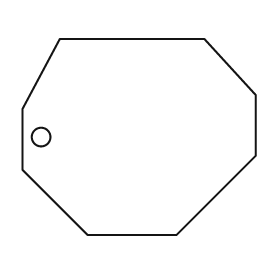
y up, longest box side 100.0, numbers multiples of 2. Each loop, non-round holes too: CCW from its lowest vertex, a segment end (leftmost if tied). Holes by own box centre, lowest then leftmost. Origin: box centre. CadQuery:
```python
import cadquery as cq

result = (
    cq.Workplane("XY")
    .moveTo(-22.0, -42.0)
    .lineTo(16.0, -42.0)
    .lineTo(50.0, -8.0)
    .lineTo(50.0, 18.0)
    .lineTo(28.0, 42.0)
    .lineTo(-34.0, 42.0)
    .lineTo(-50.0, 12.0)
    .lineTo(-50.0, -14.0)
    .close()
    .moveTo(-42.0, 0.0)
    .circle(4.0)
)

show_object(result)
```